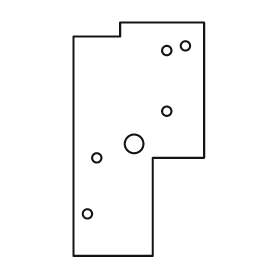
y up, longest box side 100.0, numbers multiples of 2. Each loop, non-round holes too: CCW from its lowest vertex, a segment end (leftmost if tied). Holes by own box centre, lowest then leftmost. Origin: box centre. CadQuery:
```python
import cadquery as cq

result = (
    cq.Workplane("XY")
    .moveTo(-28.0, -50.0)
    .lineTo(6.0, -50.0)
    .lineTo(6.0, -8.0)
    .lineTo(28.0, -8.0)
    .lineTo(28.0, 50.0)
    .lineTo(-8.0, 50.0)
    .lineTo(-8.0, 44.0)
    .lineTo(-28.0, 44.0)
    .close()
    .moveTo(-22.0, -32.0)
    .circle(2.0)
    .moveTo(-18.0, -8.0)
    .circle(2.0)
    .moveTo(-2.0, -2.0)
    .circle(4.0)
    .moveTo(12.0, 12.0)
    .circle(2.0)
    .moveTo(12.0, 38.0)
    .circle(2.0)
    .moveTo(20.0, 40.0)
    .circle(2.0)
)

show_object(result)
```